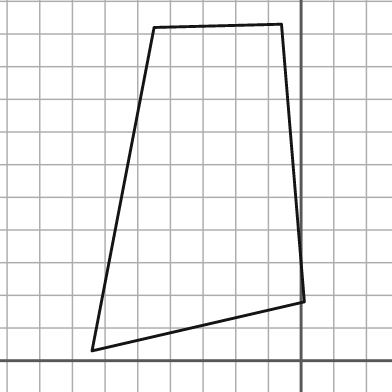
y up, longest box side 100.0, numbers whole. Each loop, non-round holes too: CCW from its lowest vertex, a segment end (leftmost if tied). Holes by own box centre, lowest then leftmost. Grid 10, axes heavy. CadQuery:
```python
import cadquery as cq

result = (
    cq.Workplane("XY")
    .moveTo(-64.0, 3.0)
    .lineTo(1.0, 18.0)
    .lineTo(-6.0, 103.0)
    .lineTo(-45.0, 102.0)
    .close()
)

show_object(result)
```